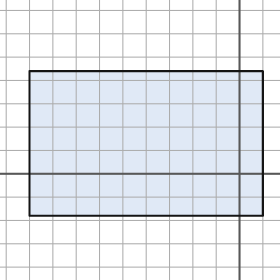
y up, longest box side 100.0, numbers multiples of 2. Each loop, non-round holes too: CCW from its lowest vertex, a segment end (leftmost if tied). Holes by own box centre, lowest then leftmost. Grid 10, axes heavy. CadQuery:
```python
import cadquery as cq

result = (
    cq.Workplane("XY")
    .moveTo(-90.0, -18.0)
    .lineTo(10.0, -18.0)
    .lineTo(10.0, 44.0)
    .lineTo(-90.0, 44.0)
    .close()
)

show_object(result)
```